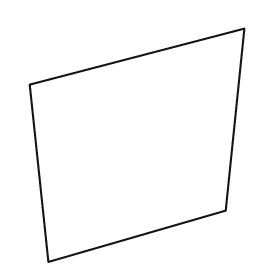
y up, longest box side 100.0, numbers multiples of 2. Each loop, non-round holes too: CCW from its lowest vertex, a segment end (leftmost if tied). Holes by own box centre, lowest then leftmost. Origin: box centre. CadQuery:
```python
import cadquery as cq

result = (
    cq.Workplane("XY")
    .moveTo(-38.0, -50.0)
    .lineTo(38.0, -28.0)
    .lineTo(46.0, 50.0)
    .lineTo(-46.0, 26.0)
    .close()
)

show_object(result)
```